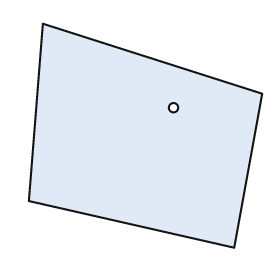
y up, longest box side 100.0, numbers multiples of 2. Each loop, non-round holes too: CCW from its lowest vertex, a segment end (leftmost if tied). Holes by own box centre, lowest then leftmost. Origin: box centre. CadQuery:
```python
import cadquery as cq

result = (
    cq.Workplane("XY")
    .moveTo(38.0, -48.0)
    .lineTo(50.0, 18.0)
    .lineTo(-44.0, 48.0)
    .lineTo(-50.0, -28.0)
    .close()
    .moveTo(12.0, 12.0)
    .circle(2.0)
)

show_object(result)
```